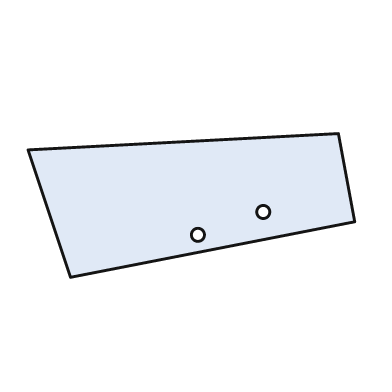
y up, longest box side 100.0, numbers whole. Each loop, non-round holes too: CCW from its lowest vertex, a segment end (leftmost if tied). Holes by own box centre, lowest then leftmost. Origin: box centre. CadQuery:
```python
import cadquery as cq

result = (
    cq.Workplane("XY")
    .moveTo(-37.0, -22.0)
    .lineTo(50.0, -5.0)
    .lineTo(45.0, 22.0)
    .lineTo(-50.0, 17.0)
    .close()
    .moveTo(2.0, -9.0)
    .circle(2.0)
    .moveTo(22.0, -2.0)
    .circle(2.0)
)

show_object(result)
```